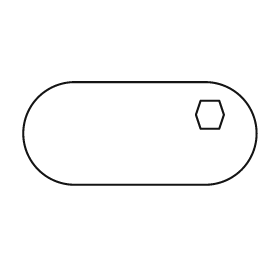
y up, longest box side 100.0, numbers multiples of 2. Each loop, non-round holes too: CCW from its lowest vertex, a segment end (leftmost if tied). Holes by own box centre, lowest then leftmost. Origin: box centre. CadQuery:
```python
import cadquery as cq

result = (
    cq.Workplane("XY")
    .moveTo(-28.0, -22.0)
    .lineTo(28.0, -22.0)
    .threePointArc((50.0, 0.0), (28.0, 22.0))
    .lineTo(-28.0, 22.0)
    .threePointArc((-50.0, 0.0), (-28.0, -22.0))
    .close()
    .moveTo(26.0, 2.0)
    .lineTo(34.0, 2.0)
    .lineTo(36.0, 8.0)
    .lineTo(34.0, 14.0)
    .lineTo(26.0, 14.0)
    .lineTo(24.0, 8.0)
    .close()
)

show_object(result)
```